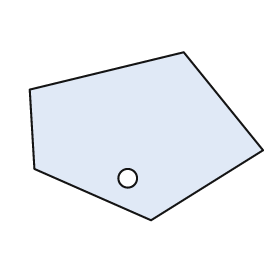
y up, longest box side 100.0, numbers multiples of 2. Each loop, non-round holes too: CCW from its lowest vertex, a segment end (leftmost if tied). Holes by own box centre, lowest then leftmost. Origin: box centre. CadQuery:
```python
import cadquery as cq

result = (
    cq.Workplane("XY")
    .moveTo(2.0, -36.0)
    .lineTo(50.0, -6.0)
    .lineTo(16.0, 36.0)
    .lineTo(-50.0, 20.0)
    .lineTo(-48.0, -14.0)
    .close()
    .moveTo(-8.0, -18.0)
    .circle(4.0)
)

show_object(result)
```